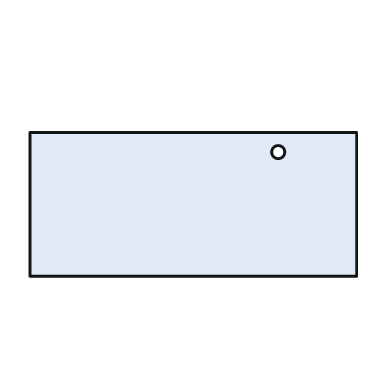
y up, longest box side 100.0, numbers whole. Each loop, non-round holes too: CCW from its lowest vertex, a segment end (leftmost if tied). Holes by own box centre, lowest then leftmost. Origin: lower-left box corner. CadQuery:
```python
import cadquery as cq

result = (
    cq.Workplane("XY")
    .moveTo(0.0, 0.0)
    .lineTo(100.0, 0.0)
    .lineTo(100.0, 44.0)
    .lineTo(0.0, 44.0)
    .close()
    .moveTo(76.0, 38.0)
    .circle(2.0)
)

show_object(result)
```